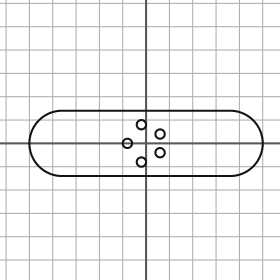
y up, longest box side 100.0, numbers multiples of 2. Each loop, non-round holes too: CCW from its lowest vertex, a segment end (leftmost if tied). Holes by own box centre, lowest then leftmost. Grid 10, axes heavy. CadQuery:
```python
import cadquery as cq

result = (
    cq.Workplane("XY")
    .moveTo(-36.0, -14.0)
    .lineTo(36.0, -14.0)
    .threePointArc((50.0, 0.0), (36.0, 14.0))
    .lineTo(-36.0, 14.0)
    .threePointArc((-50.0, 0.0), (-36.0, -14.0))
    .close()
    .moveTo(-2.0, -8.0)
    .circle(2.0)
    .moveTo(6.0, -4.0)
    .circle(2.0)
    .moveTo(-8.0, 0.0)
    .circle(2.0)
    .moveTo(6.0, 4.0)
    .circle(2.0)
    .moveTo(-2.0, 8.0)
    .circle(2.0)
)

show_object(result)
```